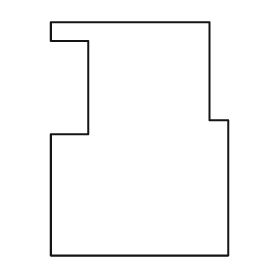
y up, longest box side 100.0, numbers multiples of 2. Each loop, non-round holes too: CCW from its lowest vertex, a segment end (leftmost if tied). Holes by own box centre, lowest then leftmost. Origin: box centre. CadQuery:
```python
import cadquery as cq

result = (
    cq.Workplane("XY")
    .moveTo(-38.0, -50.0)
    .lineTo(38.0, -50.0)
    .lineTo(38.0, 8.0)
    .lineTo(30.0, 8.0)
    .lineTo(30.0, 50.0)
    .lineTo(-38.0, 50.0)
    .lineTo(-38.0, 42.0)
    .lineTo(-22.0, 42.0)
    .lineTo(-22.0, 2.0)
    .lineTo(-38.0, 2.0)
    .close()
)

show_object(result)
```